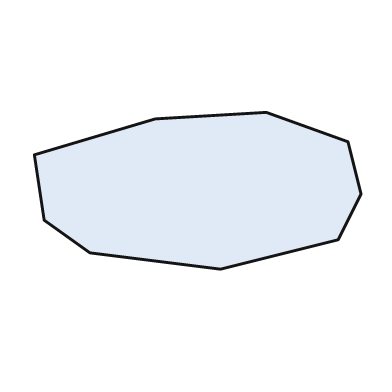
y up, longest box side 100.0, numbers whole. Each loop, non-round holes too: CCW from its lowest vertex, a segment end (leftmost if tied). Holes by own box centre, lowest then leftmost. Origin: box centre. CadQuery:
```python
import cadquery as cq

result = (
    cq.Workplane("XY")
    .moveTo(7.0, -24.0)
    .lineTo(43.0, -15.0)
    .lineTo(50.0, -1.0)
    .lineTo(46.0, 15.0)
    .lineTo(21.0, 24.0)
    .lineTo(-13.0, 22.0)
    .lineTo(-50.0, 11.0)
    .lineTo(-47.0, -9.0)
    .lineTo(-33.0, -19.0)
    .close()
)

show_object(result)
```